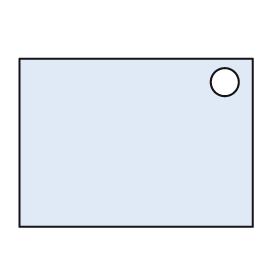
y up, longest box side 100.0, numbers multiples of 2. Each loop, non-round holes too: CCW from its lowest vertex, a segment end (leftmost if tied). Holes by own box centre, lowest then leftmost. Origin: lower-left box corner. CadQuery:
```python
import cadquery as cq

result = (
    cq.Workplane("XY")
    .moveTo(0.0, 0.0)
    .lineTo(100.0, 0.0)
    .lineTo(100.0, 72.0)
    .lineTo(0.0, 72.0)
    .close()
    .moveTo(88.0, 62.0)
    .circle(6.0)
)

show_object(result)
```